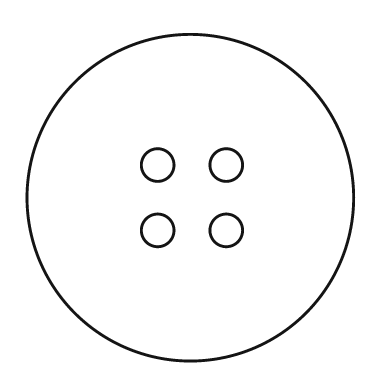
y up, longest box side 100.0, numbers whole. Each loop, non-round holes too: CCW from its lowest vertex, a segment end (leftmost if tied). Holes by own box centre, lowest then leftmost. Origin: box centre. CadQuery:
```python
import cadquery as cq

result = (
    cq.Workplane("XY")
    .moveTo(0.0, 0.0)
    .circle(50.0)
    .moveTo(-10.0, -10.0)
    .circle(5.0)
    .moveTo(11.0, -10.0)
    .circle(5.0)
    .moveTo(-10.0, 10.0)
    .circle(5.0)
    .moveTo(11.0, 10.0)
    .circle(5.0)
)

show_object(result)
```